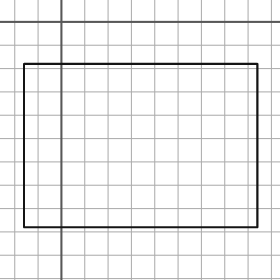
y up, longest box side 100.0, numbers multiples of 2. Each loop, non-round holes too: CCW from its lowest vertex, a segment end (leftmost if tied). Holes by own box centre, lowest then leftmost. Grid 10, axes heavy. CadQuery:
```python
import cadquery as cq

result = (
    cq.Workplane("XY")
    .moveTo(-16.0, -88.0)
    .lineTo(84.0, -88.0)
    .lineTo(84.0, -18.0)
    .lineTo(-16.0, -18.0)
    .close()
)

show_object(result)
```